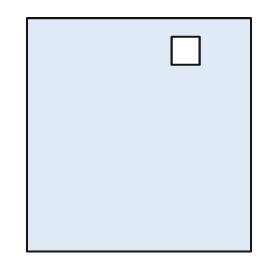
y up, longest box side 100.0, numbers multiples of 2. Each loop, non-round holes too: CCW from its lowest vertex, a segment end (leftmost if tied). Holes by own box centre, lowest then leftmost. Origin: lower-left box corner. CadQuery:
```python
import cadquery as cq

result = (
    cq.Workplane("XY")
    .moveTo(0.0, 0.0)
    .lineTo(96.0, 0.0)
    .lineTo(96.0, 100.0)
    .lineTo(0.0, 100.0)
    .close()
    .moveTo(62.0, 80.0)
    .lineTo(74.0, 80.0)
    .lineTo(74.0, 92.0)
    .lineTo(62.0, 92.0)
    .close()
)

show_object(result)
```